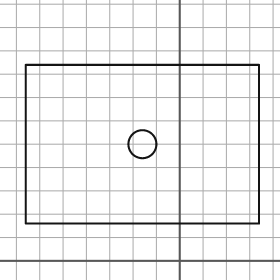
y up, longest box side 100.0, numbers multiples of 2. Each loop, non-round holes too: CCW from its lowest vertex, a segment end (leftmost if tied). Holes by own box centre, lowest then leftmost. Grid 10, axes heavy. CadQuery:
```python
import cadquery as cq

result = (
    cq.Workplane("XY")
    .moveTo(-66.0, 16.0)
    .lineTo(34.0, 16.0)
    .lineTo(34.0, 84.0)
    .lineTo(-66.0, 84.0)
    .close()
    .moveTo(-16.0, 50.0)
    .circle(6.0)
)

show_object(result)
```